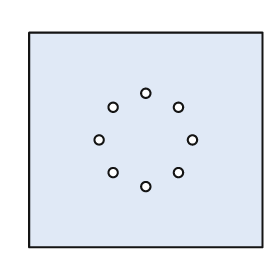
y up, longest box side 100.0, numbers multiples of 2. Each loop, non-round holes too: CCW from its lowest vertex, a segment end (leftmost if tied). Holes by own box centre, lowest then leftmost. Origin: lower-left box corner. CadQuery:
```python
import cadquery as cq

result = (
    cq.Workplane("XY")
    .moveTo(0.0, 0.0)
    .lineTo(100.0, 0.0)
    .lineTo(100.0, 92.0)
    .lineTo(0.0, 92.0)
    .close()
    .moveTo(50.0, 26.0)
    .circle(2.0)
    .moveTo(36.0, 32.0)
    .circle(2.0)
    .moveTo(64.0, 32.0)
    .circle(2.0)
    .moveTo(30.0, 46.0)
    .circle(2.0)
    .moveTo(70.0, 46.0)
    .circle(2.0)
    .moveTo(36.0, 60.0)
    .circle(2.0)
    .moveTo(64.0, 60.0)
    .circle(2.0)
    .moveTo(50.0, 66.0)
    .circle(2.0)
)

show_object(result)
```